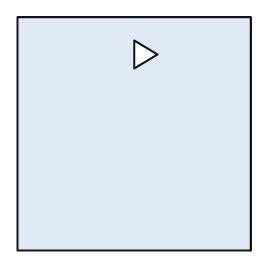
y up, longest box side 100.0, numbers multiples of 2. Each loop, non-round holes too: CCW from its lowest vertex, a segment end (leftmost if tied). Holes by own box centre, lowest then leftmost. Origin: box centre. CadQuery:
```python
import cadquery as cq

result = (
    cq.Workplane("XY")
    .moveTo(-50.0, -50.0)
    .lineTo(50.0, -50.0)
    .lineTo(50.0, 50.0)
    .lineTo(-50.0, 50.0)
    .close()
    .moveTo(0.0, 28.0)
    .lineTo(10.0, 34.0)
    .lineTo(0.0, 40.0)
    .close()
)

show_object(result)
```